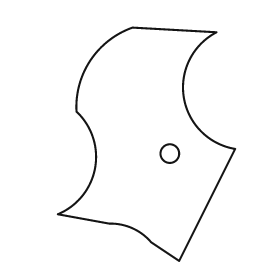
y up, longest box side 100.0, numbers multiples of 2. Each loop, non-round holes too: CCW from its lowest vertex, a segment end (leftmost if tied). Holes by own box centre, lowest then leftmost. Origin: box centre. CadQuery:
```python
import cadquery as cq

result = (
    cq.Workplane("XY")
    .moveTo(14.0, -50.0)
    .lineTo(38.0, -2.0)
    .threePointArc((16.0, 20.0), (30.0, 48.0))
    .lineTo(-6.0, 50.0)
    .threePointArc((-24.0, 36.0), (-30.0, 14.0))
    .threePointArc((-22.0, -10.0), (-38.0, -30.0))
    .lineTo(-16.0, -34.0)
    .threePointArc((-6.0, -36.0), (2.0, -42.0))
    .close()
    .moveTo(10.0, -4.0)
    .circle(4.0)
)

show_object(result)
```